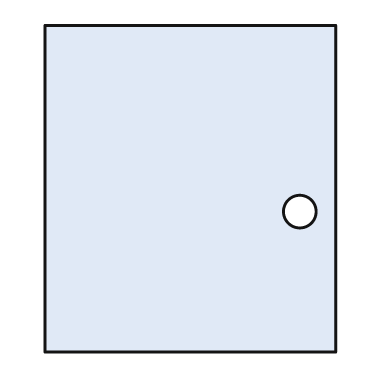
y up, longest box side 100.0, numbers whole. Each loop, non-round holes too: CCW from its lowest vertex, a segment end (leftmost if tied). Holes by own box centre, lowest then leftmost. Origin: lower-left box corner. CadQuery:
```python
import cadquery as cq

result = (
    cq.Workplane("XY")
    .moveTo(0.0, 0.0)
    .lineTo(89.0, 0.0)
    .lineTo(89.0, 100.0)
    .lineTo(0.0, 100.0)
    .close()
    .moveTo(78.0, 43.0)
    .circle(5.0)
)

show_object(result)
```